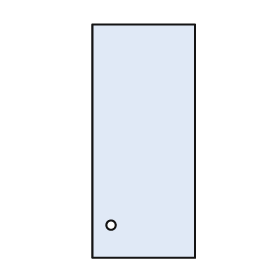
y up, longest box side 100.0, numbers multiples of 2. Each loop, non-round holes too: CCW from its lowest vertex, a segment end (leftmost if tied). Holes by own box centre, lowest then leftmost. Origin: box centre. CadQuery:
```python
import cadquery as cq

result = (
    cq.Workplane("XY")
    .moveTo(-22.0, -50.0)
    .lineTo(22.0, -50.0)
    .lineTo(22.0, 50.0)
    .lineTo(-22.0, 50.0)
    .close()
    .moveTo(-14.0, -36.0)
    .circle(2.0)
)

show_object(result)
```